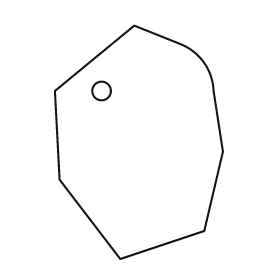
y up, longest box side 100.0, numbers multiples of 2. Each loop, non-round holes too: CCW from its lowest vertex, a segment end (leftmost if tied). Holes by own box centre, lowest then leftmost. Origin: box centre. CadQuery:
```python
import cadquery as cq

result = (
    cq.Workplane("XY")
    .moveTo(-8.0, -50.0)
    .lineTo(28.0, -38.0)
    .lineTo(36.0, -4.0)
    .lineTo(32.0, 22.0)
    .threePointArc((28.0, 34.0), (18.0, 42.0))
    .lineTo(-2.0, 50.0)
    .lineTo(-36.0, 22.0)
    .lineTo(-34.0, -16.0)
    .close()
    .moveTo(-16.0, 22.0)
    .circle(4.0)
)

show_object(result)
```